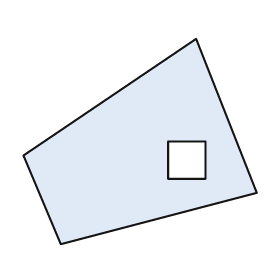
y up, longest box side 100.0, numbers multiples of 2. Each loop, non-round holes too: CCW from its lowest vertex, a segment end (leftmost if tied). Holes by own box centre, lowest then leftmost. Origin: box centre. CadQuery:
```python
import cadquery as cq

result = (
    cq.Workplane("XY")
    .moveTo(-34.0, -44.0)
    .lineTo(50.0, -22.0)
    .lineTo(24.0, 44.0)
    .lineTo(-50.0, -6.0)
    .close()
    .moveTo(12.0, -16.0)
    .lineTo(28.0, -16.0)
    .lineTo(28.0, 0.0)
    .lineTo(12.0, 0.0)
    .close()
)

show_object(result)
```